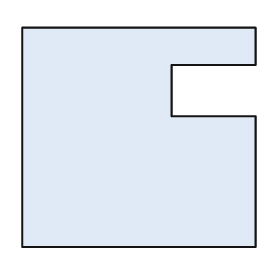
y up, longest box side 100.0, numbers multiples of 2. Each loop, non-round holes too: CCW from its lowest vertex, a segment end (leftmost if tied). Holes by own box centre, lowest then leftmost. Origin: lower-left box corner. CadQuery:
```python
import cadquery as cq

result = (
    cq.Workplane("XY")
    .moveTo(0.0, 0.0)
    .lineTo(100.0, 0.0)
    .lineTo(100.0, 56.0)
    .lineTo(64.0, 56.0)
    .lineTo(64.0, 78.0)
    .lineTo(100.0, 78.0)
    .lineTo(100.0, 94.0)
    .lineTo(0.0, 94.0)
    .close()
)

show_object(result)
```